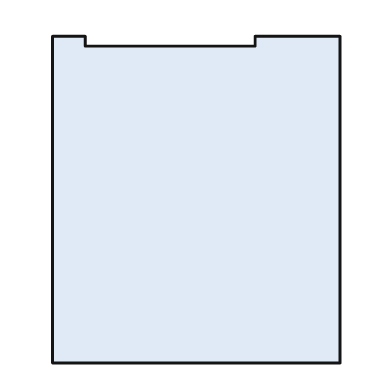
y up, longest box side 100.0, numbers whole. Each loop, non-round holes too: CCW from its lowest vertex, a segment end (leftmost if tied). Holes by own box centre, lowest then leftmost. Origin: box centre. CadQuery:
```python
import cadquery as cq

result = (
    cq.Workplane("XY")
    .moveTo(-44.0, -50.0)
    .lineTo(44.0, -50.0)
    .lineTo(44.0, 50.0)
    .lineTo(18.0, 50.0)
    .lineTo(18.0, 47.0)
    .lineTo(-34.0, 47.0)
    .lineTo(-34.0, 50.0)
    .lineTo(-44.0, 50.0)
    .close()
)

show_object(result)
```